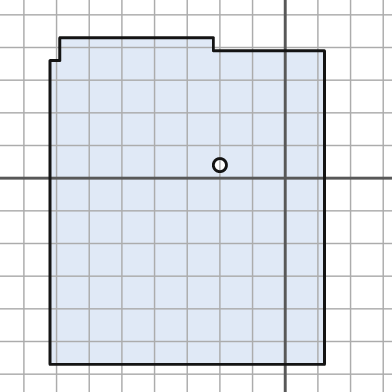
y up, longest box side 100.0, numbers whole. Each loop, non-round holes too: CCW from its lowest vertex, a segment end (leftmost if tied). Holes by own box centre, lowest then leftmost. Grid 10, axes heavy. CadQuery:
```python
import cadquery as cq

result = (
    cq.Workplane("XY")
    .moveTo(-72.0, -57.0)
    .lineTo(12.0, -57.0)
    .lineTo(12.0, 39.0)
    .lineTo(-22.0, 39.0)
    .lineTo(-22.0, 43.0)
    .lineTo(-69.0, 43.0)
    .lineTo(-69.0, 36.0)
    .lineTo(-72.0, 36.0)
    .close()
    .moveTo(-20.0, 4.0)
    .circle(2.0)
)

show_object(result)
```